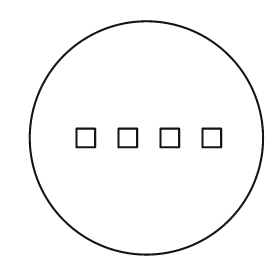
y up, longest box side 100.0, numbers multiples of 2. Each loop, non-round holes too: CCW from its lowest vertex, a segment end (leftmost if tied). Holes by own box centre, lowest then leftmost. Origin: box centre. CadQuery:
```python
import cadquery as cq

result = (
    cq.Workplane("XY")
    .moveTo(0.0, 0.0)
    .circle(50.0)
    .moveTo(-30.0, -4.0)
    .lineTo(-22.0, -4.0)
    .lineTo(-22.0, 4.0)
    .lineTo(-30.0, 4.0)
    .close()
    .moveTo(-12.0, -4.0)
    .lineTo(-4.0, -4.0)
    .lineTo(-4.0, 4.0)
    .lineTo(-12.0, 4.0)
    .close()
    .moveTo(6.0, -4.0)
    .lineTo(14.0, -4.0)
    .lineTo(14.0, 4.0)
    .lineTo(6.0, 4.0)
    .close()
    .moveTo(24.0, -4.0)
    .lineTo(32.0, -4.0)
    .lineTo(32.0, 4.0)
    .lineTo(24.0, 4.0)
    .close()
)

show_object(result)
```